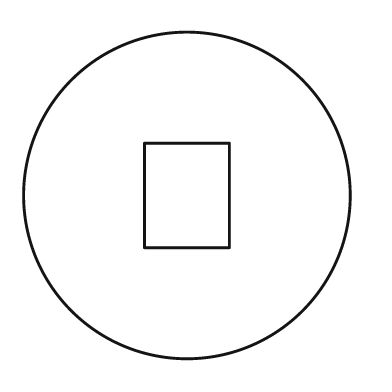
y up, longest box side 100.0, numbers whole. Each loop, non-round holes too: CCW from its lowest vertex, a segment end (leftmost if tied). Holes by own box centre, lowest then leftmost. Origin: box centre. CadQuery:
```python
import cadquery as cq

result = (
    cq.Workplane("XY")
    .moveTo(0.0, 0.0)
    .circle(50.0)
    .moveTo(-13.0, -16.0)
    .lineTo(13.0, -16.0)
    .lineTo(13.0, 16.0)
    .lineTo(-13.0, 16.0)
    .close()
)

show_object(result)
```